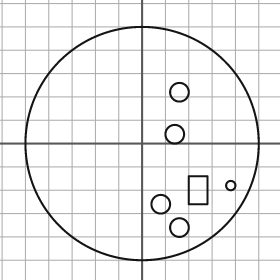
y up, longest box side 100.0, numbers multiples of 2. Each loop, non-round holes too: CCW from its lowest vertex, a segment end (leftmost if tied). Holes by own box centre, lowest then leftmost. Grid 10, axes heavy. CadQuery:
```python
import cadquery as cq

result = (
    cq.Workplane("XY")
    .moveTo(0.0, 0.0)
    .circle(50.0)
    .moveTo(16.0, -36.0)
    .circle(4.0)
    .moveTo(8.0, -26.0)
    .circle(4.0)
    .moveTo(20.0, -26.0)
    .lineTo(28.0, -26.0)
    .lineTo(28.0, -14.0)
    .lineTo(20.0, -14.0)
    .close()
    .moveTo(38.0, -18.0)
    .circle(2.0)
    .moveTo(14.0, 4.0)
    .circle(4.0)
    .moveTo(16.0, 22.0)
    .circle(4.0)
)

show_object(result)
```